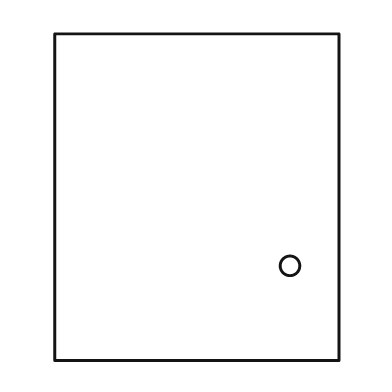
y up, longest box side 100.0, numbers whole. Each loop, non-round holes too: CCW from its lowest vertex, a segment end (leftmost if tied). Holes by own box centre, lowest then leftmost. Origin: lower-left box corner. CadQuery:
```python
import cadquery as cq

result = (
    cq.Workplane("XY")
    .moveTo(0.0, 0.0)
    .lineTo(87.0, 0.0)
    .lineTo(87.0, 100.0)
    .lineTo(0.0, 100.0)
    .close()
    .moveTo(72.0, 29.0)
    .circle(3.0)
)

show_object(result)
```